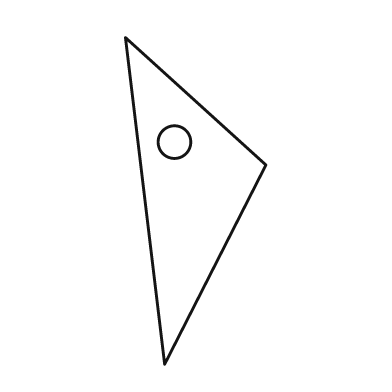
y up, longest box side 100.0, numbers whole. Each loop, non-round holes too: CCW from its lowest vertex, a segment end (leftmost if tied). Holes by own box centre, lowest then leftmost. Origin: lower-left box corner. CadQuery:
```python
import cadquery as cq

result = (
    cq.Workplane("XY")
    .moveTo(12.0, 0.0)
    .lineTo(43.0, 61.0)
    .lineTo(0.0, 100.0)
    .close()
    .moveTo(15.0, 68.0)
    .circle(5.0)
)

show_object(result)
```